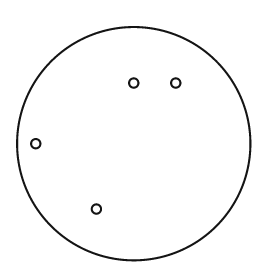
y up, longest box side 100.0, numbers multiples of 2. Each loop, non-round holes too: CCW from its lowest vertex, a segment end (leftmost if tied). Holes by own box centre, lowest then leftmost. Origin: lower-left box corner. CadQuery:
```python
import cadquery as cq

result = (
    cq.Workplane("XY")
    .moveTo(50.0, 50.0)
    .circle(50.0)
    .moveTo(34.0, 22.0)
    .circle(2.0)
    .moveTo(8.0, 50.0)
    .circle(2.0)
    .moveTo(50.0, 76.0)
    .circle(2.0)
    .moveTo(68.0, 76.0)
    .circle(2.0)
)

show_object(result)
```